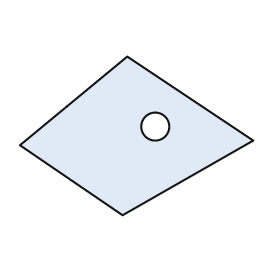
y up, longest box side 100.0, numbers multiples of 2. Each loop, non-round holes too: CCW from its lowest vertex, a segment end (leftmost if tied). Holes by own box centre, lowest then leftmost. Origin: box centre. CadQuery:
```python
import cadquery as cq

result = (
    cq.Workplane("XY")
    .moveTo(-6.0, -34.0)
    .lineTo(50.0, -2.0)
    .lineTo(-4.0, 34.0)
    .lineTo(-50.0, -4.0)
    .close()
    .moveTo(8.0, 4.0)
    .circle(6.0)
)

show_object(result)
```